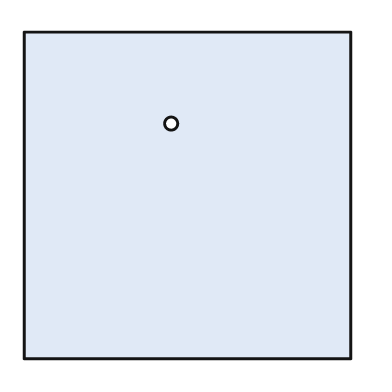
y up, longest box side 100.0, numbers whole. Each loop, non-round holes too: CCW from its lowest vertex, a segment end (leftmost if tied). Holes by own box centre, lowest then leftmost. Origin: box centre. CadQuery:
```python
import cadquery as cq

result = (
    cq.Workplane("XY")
    .moveTo(-50.0, -50.0)
    .lineTo(50.0, -50.0)
    .lineTo(50.0, 50.0)
    .lineTo(-50.0, 50.0)
    .close()
    .moveTo(-5.0, 22.0)
    .circle(2.0)
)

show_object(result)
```